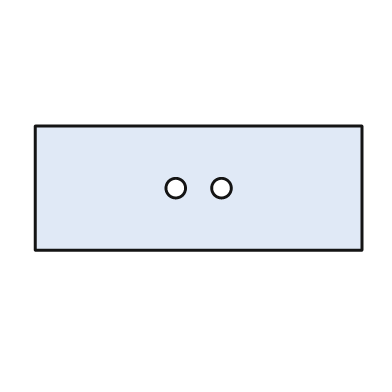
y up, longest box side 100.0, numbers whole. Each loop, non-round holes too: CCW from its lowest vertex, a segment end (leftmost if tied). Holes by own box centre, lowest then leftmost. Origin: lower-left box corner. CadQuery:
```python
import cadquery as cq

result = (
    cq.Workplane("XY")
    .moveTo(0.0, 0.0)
    .lineTo(100.0, 0.0)
    .lineTo(100.0, 38.0)
    .lineTo(0.0, 38.0)
    .close()
    .moveTo(43.0, 19.0)
    .circle(3.0)
    .moveTo(57.0, 19.0)
    .circle(3.0)
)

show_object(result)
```